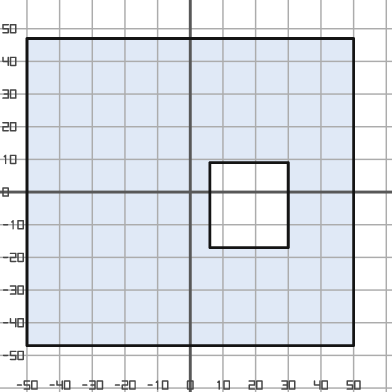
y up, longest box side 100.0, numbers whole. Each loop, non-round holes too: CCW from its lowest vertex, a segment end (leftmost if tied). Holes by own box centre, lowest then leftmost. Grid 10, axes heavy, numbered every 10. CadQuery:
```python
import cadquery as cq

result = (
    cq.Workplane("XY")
    .moveTo(-50.0, -47.0)
    .lineTo(50.0, -47.0)
    .lineTo(50.0, 47.0)
    .lineTo(-50.0, 47.0)
    .close()
    .moveTo(6.0, -17.0)
    .lineTo(30.0, -17.0)
    .lineTo(30.0, 9.0)
    .lineTo(6.0, 9.0)
    .close()
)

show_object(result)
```